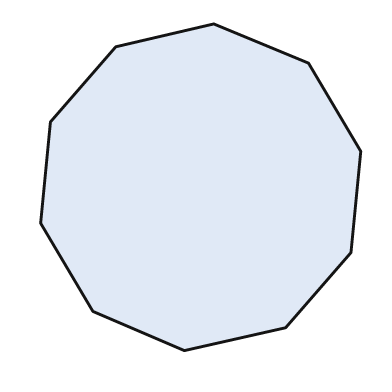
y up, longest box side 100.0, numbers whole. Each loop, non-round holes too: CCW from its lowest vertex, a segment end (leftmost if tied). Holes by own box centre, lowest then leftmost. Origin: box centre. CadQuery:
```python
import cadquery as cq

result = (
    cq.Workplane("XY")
    .moveTo(-5.0, -50.0)
    .lineTo(26.0, -43.0)
    .lineTo(46.0, -20.0)
    .lineTo(49.0, 11.0)
    .lineTo(33.0, 38.0)
    .lineTo(4.0, 50.0)
    .lineTo(-26.0, 43.0)
    .lineTo(-46.0, 20.0)
    .lineTo(-49.0, -11.0)
    .lineTo(-33.0, -38.0)
    .close()
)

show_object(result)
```